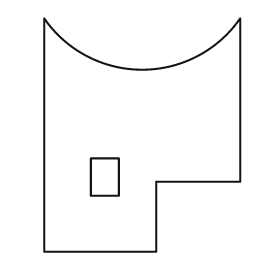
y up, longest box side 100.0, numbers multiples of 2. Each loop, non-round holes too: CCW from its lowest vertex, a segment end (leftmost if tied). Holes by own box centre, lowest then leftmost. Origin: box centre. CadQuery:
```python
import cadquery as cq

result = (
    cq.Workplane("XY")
    .moveTo(-42.0, -50.0)
    .lineTo(6.0, -50.0)
    .lineTo(6.0, -20.0)
    .lineTo(42.0, -20.0)
    .lineTo(42.0, 50.0)
    .threePointArc((0.0, 28.0), (-42.0, 50.0))
    .close()
    .moveTo(-22.0, -26.0)
    .lineTo(-10.0, -26.0)
    .lineTo(-10.0, -10.0)
    .lineTo(-22.0, -10.0)
    .close()
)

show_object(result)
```